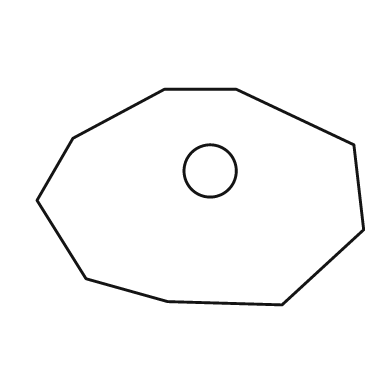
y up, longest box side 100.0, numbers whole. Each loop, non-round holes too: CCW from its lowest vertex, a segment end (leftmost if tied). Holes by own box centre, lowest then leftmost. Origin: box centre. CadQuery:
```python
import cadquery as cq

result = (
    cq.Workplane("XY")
    .moveTo(25.0, -33.0)
    .lineTo(50.0, -10.0)
    .lineTo(47.0, 16.0)
    .lineTo(11.0, 33.0)
    .lineTo(-11.0, 33.0)
    .lineTo(-39.0, 18.0)
    .lineTo(-50.0, -1.0)
    .lineTo(-35.0, -25.0)
    .lineTo(-10.0, -32.0)
    .close()
    .moveTo(3.0, 8.0)
    .circle(8.0)
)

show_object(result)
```